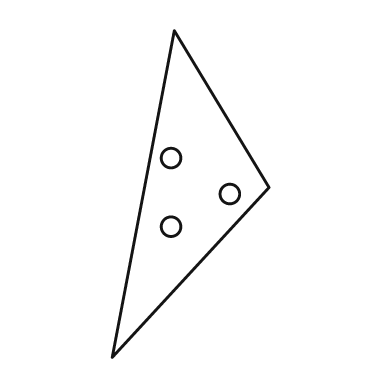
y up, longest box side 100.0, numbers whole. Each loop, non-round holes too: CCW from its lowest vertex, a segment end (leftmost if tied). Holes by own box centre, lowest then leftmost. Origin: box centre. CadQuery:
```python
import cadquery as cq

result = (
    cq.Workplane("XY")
    .moveTo(-24.0, -50.0)
    .lineTo(24.0, 2.0)
    .lineTo(-5.0, 50.0)
    .close()
    .moveTo(-6.0, -10.0)
    .circle(3.0)
    .moveTo(12.0, 0.0)
    .circle(3.0)
    .moveTo(-6.0, 11.0)
    .circle(3.0)
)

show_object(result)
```